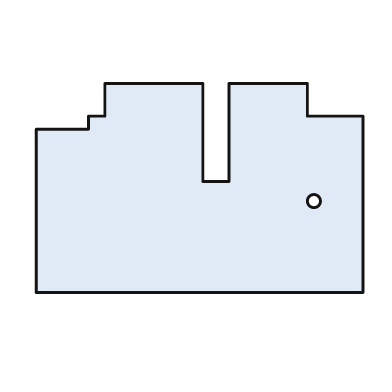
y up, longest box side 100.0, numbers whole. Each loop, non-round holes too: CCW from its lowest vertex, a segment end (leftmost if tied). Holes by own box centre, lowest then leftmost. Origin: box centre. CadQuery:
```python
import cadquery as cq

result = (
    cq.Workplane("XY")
    .moveTo(-50.0, -32.0)
    .lineTo(50.0, -32.0)
    .lineTo(50.0, 22.0)
    .lineTo(33.0, 22.0)
    .lineTo(33.0, 32.0)
    .lineTo(9.0, 32.0)
    .lineTo(9.0, 2.0)
    .lineTo(1.0, 2.0)
    .lineTo(1.0, 32.0)
    .lineTo(-29.0, 32.0)
    .lineTo(-29.0, 22.0)
    .lineTo(-34.0, 22.0)
    .lineTo(-34.0, 18.0)
    .lineTo(-50.0, 18.0)
    .close()
    .moveTo(35.0, -4.0)
    .circle(2.0)
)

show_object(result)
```